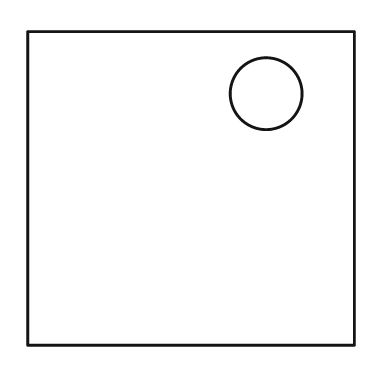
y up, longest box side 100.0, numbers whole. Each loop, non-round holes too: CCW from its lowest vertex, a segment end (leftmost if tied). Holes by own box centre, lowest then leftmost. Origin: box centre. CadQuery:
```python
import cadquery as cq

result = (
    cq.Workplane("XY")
    .moveTo(-50.0, -48.0)
    .lineTo(50.0, -48.0)
    .lineTo(50.0, 48.0)
    .lineTo(-50.0, 48.0)
    .close()
    .moveTo(23.0, 29.0)
    .circle(11.0)
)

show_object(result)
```